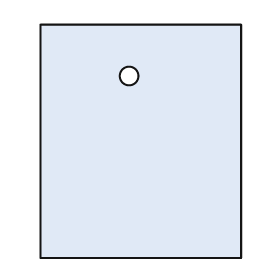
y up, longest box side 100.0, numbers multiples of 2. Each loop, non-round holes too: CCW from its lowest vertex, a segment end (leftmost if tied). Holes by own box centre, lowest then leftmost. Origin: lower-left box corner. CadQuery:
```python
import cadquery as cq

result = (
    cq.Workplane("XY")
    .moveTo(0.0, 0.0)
    .lineTo(86.0, 0.0)
    .lineTo(86.0, 100.0)
    .lineTo(0.0, 100.0)
    .close()
    .moveTo(38.0, 78.0)
    .circle(4.0)
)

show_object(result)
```